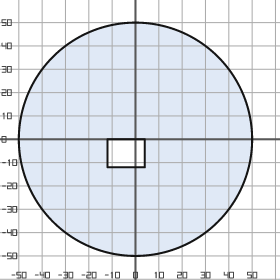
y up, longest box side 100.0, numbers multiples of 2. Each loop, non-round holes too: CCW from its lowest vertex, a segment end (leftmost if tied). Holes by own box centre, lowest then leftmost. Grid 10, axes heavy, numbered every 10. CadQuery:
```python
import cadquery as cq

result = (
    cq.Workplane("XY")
    .moveTo(0.0, 0.0)
    .circle(50.0)
    .moveTo(-12.0, -12.0)
    .lineTo(4.0, -12.0)
    .lineTo(4.0, 0.0)
    .lineTo(-12.0, 0.0)
    .close()
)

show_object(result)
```